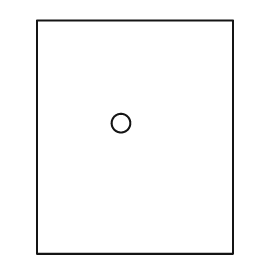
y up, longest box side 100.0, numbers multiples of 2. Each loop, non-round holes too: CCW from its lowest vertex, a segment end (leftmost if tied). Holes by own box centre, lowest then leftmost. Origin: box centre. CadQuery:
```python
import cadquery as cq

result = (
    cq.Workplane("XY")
    .moveTo(-42.0, -50.0)
    .lineTo(42.0, -50.0)
    .lineTo(42.0, 50.0)
    .lineTo(-42.0, 50.0)
    .close()
    .moveTo(-6.0, 6.0)
    .circle(4.0)
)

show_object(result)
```